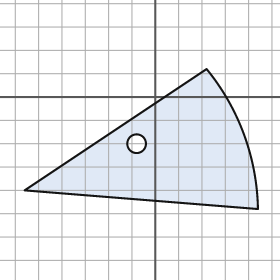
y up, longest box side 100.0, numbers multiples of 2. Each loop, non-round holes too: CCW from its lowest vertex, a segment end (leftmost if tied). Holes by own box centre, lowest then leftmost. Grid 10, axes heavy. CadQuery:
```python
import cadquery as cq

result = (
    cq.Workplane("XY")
    .moveTo(44.0, -48.0)
    .threePointArc((38.0, -16.0), (22.0, 12.0))
    .lineTo(-56.0, -40.0)
    .close()
    .moveTo(-8.0, -20.0)
    .circle(4.0)
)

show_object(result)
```